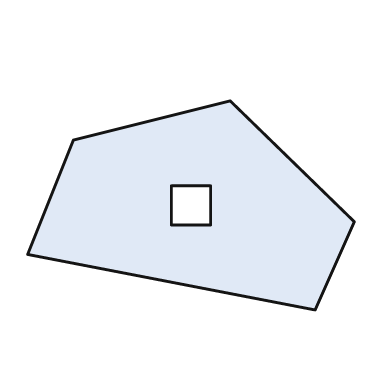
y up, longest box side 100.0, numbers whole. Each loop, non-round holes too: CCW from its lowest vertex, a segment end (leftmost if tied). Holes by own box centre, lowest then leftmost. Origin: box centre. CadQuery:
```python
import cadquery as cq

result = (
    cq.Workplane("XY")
    .moveTo(38.0, -32.0)
    .lineTo(50.0, -5.0)
    .lineTo(12.0, 32.0)
    .lineTo(-36.0, 20.0)
    .lineTo(-50.0, -15.0)
    .close()
    .moveTo(-6.0, -6.0)
    .lineTo(6.0, -6.0)
    .lineTo(6.0, 6.0)
    .lineTo(-6.0, 6.0)
    .close()
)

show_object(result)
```